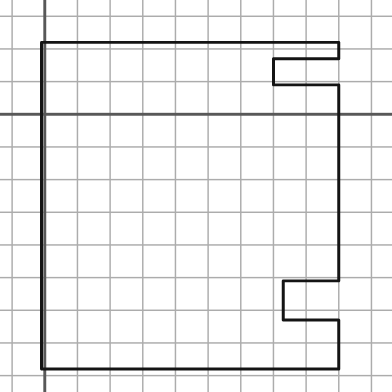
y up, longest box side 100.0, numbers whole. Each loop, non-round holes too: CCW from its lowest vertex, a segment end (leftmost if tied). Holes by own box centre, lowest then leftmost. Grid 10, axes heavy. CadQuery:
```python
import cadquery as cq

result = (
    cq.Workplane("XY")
    .moveTo(-1.0, -78.0)
    .lineTo(90.0, -78.0)
    .lineTo(90.0, -63.0)
    .lineTo(73.0, -63.0)
    .lineTo(73.0, -51.0)
    .lineTo(90.0, -51.0)
    .lineTo(90.0, 9.0)
    .lineTo(70.0, 9.0)
    .lineTo(70.0, 17.0)
    .lineTo(90.0, 17.0)
    .lineTo(90.0, 22.0)
    .lineTo(-1.0, 22.0)
    .close()
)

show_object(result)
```